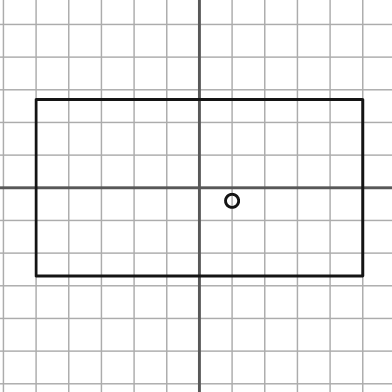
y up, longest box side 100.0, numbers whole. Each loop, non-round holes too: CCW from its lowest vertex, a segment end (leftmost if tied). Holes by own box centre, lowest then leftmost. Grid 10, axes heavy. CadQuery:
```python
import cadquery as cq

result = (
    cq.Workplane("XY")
    .moveTo(-50.0, -27.0)
    .lineTo(50.0, -27.0)
    .lineTo(50.0, 27.0)
    .lineTo(-50.0, 27.0)
    .close()
    .moveTo(10.0, -4.0)
    .circle(2.0)
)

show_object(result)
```